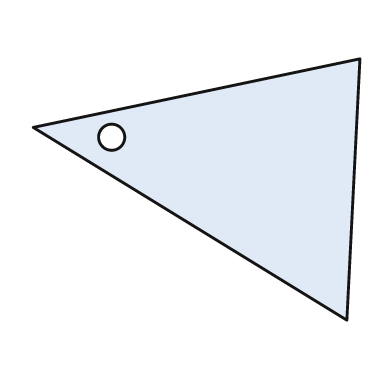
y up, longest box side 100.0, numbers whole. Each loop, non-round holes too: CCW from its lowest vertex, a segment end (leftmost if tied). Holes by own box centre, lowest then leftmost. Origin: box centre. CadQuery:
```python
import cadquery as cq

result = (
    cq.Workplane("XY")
    .moveTo(46.0, -40.0)
    .lineTo(50.0, 40.0)
    .lineTo(-50.0, 19.0)
    .close()
    .moveTo(-26.0, 16.0)
    .circle(4.0)
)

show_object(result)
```